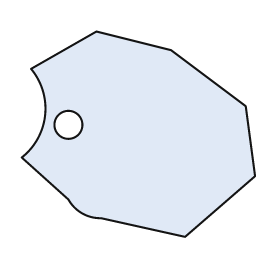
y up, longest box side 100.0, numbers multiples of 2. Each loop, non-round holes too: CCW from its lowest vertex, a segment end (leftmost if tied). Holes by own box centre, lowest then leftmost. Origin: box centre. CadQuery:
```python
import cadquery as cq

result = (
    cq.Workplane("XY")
    .moveTo(20.0, -44.0)
    .lineTo(50.0, -18.0)
    .lineTo(46.0, 12.0)
    .lineTo(14.0, 36.0)
    .lineTo(-18.0, 44.0)
    .lineTo(-46.0, 28.0)
    .threePointArc((-40.0, 8.0), (-50.0, -10.0))
    .lineTo(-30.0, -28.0)
    .threePointArc((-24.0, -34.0), (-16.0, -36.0))
    .close()
    .moveTo(-30.0, 4.0)
    .circle(6.0)
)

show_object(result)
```